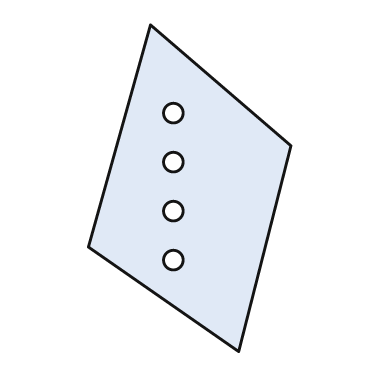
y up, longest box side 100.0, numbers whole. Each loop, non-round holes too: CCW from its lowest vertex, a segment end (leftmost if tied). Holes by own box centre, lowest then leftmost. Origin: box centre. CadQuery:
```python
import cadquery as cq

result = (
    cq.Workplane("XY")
    .moveTo(15.0, -50.0)
    .lineTo(31.0, 13.0)
    .lineTo(-12.0, 50.0)
    .lineTo(-31.0, -18.0)
    .close()
    .moveTo(-5.0, -22.0)
    .circle(3.0)
    .moveTo(-5.0, -7.0)
    .circle(3.0)
    .moveTo(-5.0, 8.0)
    .circle(3.0)
    .moveTo(-5.0, 23.0)
    .circle(3.0)
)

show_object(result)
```